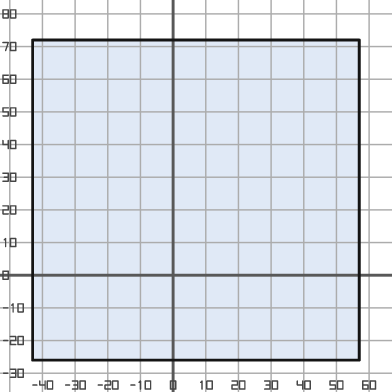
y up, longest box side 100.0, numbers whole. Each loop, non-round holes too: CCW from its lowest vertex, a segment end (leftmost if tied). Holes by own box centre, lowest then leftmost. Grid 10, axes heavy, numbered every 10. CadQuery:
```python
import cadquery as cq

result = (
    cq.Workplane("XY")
    .moveTo(-43.0, -26.0)
    .lineTo(57.0, -26.0)
    .lineTo(57.0, 72.0)
    .lineTo(-43.0, 72.0)
    .close()
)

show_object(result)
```